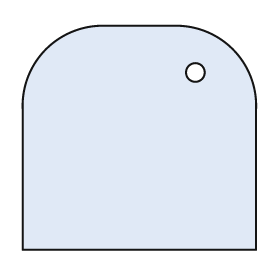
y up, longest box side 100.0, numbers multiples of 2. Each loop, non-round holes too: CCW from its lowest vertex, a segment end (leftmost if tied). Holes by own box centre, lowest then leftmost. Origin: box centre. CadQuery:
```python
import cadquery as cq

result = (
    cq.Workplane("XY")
    .moveTo(-50.0, -48.0)
    .lineTo(50.0, -48.0)
    .lineTo(50.0, 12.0)
    .threePointArc((40.0, 38.0), (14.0, 48.0))
    .lineTo(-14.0, 48.0)
    .threePointArc((-40.0, 38.0), (-50.0, 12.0))
    .close()
    .moveTo(24.0, 28.0)
    .circle(4.0)
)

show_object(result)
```